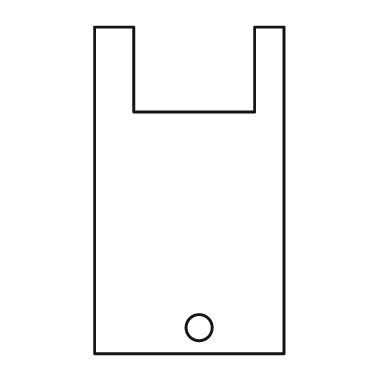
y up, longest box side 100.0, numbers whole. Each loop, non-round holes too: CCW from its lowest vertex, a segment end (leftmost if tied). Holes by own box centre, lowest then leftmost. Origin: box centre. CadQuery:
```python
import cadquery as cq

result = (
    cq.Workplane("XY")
    .moveTo(-29.0, -50.0)
    .lineTo(29.0, -50.0)
    .lineTo(29.0, 50.0)
    .lineTo(20.0, 50.0)
    .lineTo(20.0, 24.0)
    .lineTo(-17.0, 24.0)
    .lineTo(-17.0, 50.0)
    .lineTo(-29.0, 50.0)
    .close()
    .moveTo(3.0, -42.0)
    .circle(4.0)
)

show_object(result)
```